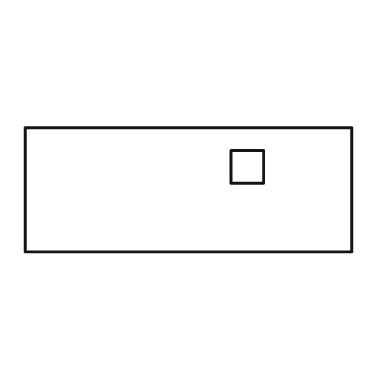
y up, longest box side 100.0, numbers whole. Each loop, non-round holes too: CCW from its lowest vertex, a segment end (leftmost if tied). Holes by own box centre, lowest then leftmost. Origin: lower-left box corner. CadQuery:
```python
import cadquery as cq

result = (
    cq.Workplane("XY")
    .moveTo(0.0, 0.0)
    .lineTo(100.0, 0.0)
    .lineTo(100.0, 38.0)
    .lineTo(0.0, 38.0)
    .close()
    .moveTo(63.0, 21.0)
    .lineTo(73.0, 21.0)
    .lineTo(73.0, 31.0)
    .lineTo(63.0, 31.0)
    .close()
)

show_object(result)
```